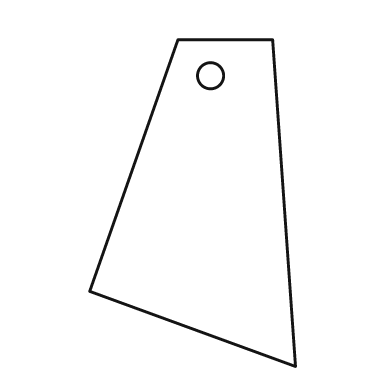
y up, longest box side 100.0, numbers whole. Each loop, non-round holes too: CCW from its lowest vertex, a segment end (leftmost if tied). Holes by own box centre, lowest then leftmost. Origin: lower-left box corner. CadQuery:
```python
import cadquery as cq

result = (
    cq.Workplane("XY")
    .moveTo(63.0, 0.0)
    .lineTo(56.0, 100.0)
    .lineTo(27.0, 100.0)
    .lineTo(0.0, 23.0)
    .close()
    .moveTo(37.0, 89.0)
    .circle(4.0)
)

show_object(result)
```